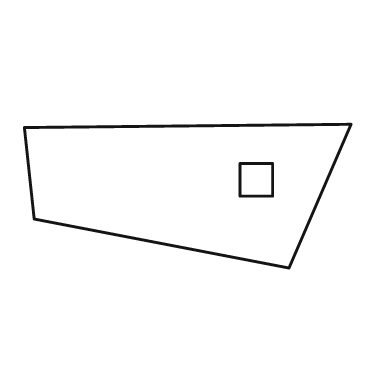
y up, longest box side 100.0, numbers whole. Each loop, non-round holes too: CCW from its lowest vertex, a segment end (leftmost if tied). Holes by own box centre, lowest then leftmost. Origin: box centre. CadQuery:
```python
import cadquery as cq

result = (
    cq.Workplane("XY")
    .moveTo(31.0, -22.0)
    .lineTo(50.0, 22.0)
    .lineTo(-50.0, 21.0)
    .lineTo(-47.0, -7.0)
    .close()
    .moveTo(16.0, 0.0)
    .lineTo(26.0, 0.0)
    .lineTo(26.0, 10.0)
    .lineTo(16.0, 10.0)
    .close()
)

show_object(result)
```